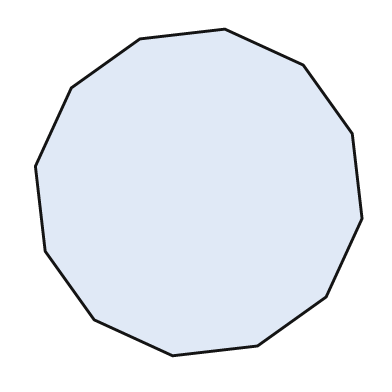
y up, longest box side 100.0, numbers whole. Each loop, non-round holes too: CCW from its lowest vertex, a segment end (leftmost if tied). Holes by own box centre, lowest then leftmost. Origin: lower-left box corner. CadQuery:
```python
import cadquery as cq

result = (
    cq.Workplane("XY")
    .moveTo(42.0, 0.0)
    .lineTo(68.0, 3.0)
    .lineTo(89.0, 18.0)
    .lineTo(100.0, 42.0)
    .lineTo(97.0, 68.0)
    .lineTo(82.0, 89.0)
    .lineTo(58.0, 100.0)
    .lineTo(32.0, 97.0)
    .lineTo(11.0, 82.0)
    .lineTo(0.0, 58.0)
    .lineTo(3.0, 32.0)
    .lineTo(18.0, 11.0)
    .close()
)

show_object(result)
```